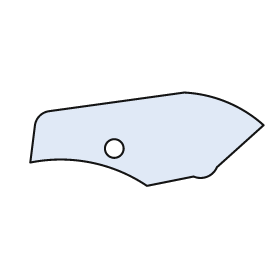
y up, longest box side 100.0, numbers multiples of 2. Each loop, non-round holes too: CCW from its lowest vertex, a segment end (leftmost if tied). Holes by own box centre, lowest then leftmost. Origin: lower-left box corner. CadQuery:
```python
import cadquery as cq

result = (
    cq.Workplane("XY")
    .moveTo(50.0, 0.0)
    .lineTo(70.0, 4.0)
    .threePointArc((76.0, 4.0), (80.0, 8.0))
    .lineTo(100.0, 26.0)
    .threePointArc((84.0, 36.0), (66.0, 40.0))
    .lineTo(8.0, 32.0)
    .threePointArc((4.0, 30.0), (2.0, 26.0))
    .lineTo(0.0, 10.0)
    .threePointArc((26.0, 10.0), (50.0, 0.0))
    .close()
    .moveTo(36.0, 16.0)
    .circle(4.0)
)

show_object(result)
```